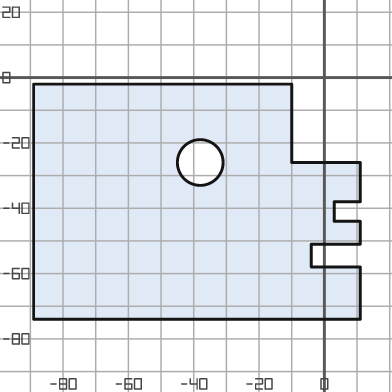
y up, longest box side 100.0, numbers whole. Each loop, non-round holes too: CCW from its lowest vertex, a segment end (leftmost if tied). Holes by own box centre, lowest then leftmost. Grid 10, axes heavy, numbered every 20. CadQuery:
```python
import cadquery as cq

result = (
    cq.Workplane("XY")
    .moveTo(-89.0, -74.0)
    .lineTo(11.0, -74.0)
    .lineTo(11.0, -58.0)
    .lineTo(-4.0, -58.0)
    .lineTo(-4.0, -51.0)
    .lineTo(11.0, -51.0)
    .lineTo(11.0, -44.0)
    .lineTo(3.0, -44.0)
    .lineTo(3.0, -38.0)
    .lineTo(11.0, -38.0)
    .lineTo(11.0, -26.0)
    .lineTo(-10.0, -26.0)
    .lineTo(-10.0, -2.0)
    .lineTo(-89.0, -2.0)
    .close()
    .moveTo(-38.0, -26.0)
    .circle(7.0)
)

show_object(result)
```